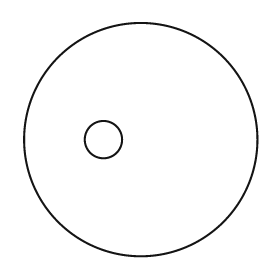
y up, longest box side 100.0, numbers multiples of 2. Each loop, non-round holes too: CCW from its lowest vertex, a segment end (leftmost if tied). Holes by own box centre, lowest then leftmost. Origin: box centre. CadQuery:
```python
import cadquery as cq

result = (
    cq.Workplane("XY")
    .moveTo(0.0, 0.0)
    .circle(50.0)
    .moveTo(-16.0, 0.0)
    .circle(8.0)
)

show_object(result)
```